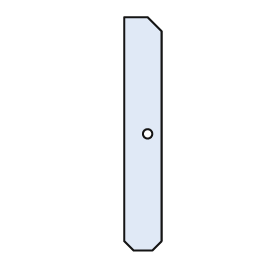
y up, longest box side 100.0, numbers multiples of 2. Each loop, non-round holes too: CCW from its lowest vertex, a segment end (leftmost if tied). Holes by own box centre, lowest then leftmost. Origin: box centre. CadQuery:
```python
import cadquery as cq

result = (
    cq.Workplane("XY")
    .moveTo(-4.0, -50.0)
    .lineTo(4.0, -50.0)
    .lineTo(8.0, -46.0)
    .lineTo(8.0, 44.0)
    .lineTo(2.0, 50.0)
    .lineTo(-8.0, 50.0)
    .lineTo(-8.0, -46.0)
    .close()
    .moveTo(2.0, 0.0)
    .circle(2.0)
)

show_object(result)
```